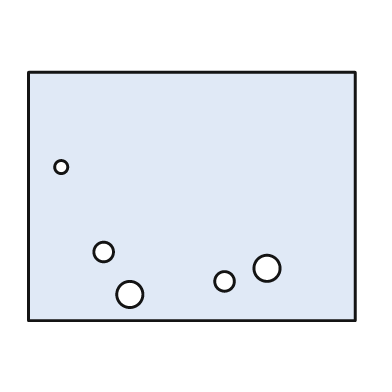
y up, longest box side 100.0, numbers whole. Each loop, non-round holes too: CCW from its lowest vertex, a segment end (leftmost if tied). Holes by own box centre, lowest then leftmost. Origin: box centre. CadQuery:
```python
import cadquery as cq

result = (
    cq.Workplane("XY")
    .moveTo(-50.0, -38.0)
    .lineTo(50.0, -38.0)
    .lineTo(50.0, 38.0)
    .lineTo(-50.0, 38.0)
    .close()
    .moveTo(-19.0, -30.0)
    .circle(4.0)
    .moveTo(10.0, -26.0)
    .circle(3.0)
    .moveTo(23.0, -22.0)
    .circle(4.0)
    .moveTo(-27.0, -17.0)
    .circle(3.0)
    .moveTo(-40.0, 9.0)
    .circle(2.0)
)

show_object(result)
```